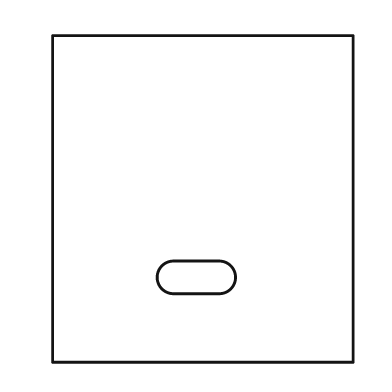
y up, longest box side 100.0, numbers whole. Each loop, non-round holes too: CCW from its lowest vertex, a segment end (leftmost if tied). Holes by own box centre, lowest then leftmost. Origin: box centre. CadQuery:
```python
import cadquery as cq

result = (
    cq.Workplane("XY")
    .moveTo(-46.0, -50.0)
    .lineTo(46.0, -50.0)
    .lineTo(46.0, 50.0)
    .lineTo(-46.0, 50.0)
    .close()
    .moveTo(-9.0, -29.0)
    .lineTo(5.0, -29.0)
    .threePointArc((10.0, -24.0), (5.0, -19.0))
    .lineTo(-9.0, -19.0)
    .threePointArc((-14.0, -24.0), (-9.0, -29.0))
    .close()
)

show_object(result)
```